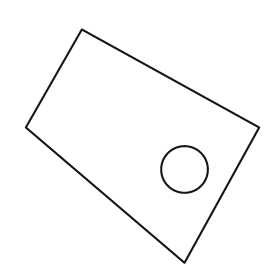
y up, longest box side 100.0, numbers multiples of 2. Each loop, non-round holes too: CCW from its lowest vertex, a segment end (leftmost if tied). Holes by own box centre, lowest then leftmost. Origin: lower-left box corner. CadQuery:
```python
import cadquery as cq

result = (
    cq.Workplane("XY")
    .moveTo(68.0, 0.0)
    .lineTo(100.0, 58.0)
    .lineTo(24.0, 100.0)
    .lineTo(0.0, 58.0)
    .close()
    .moveTo(68.0, 40.0)
    .circle(10.0)
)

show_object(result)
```